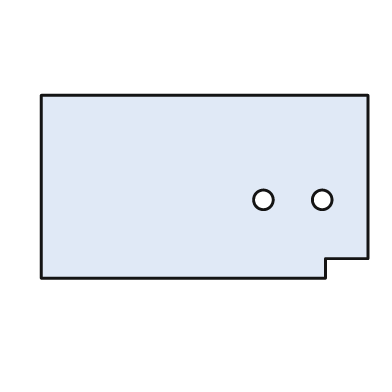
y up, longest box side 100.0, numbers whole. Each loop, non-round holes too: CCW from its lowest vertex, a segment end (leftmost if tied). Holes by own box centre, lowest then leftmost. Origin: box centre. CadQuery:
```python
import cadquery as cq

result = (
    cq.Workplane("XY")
    .moveTo(-50.0, -28.0)
    .lineTo(37.0, -28.0)
    .lineTo(37.0, -22.0)
    .lineTo(50.0, -22.0)
    .lineTo(50.0, 28.0)
    .lineTo(-50.0, 28.0)
    .close()
    .moveTo(18.0, -4.0)
    .circle(3.0)
    .moveTo(36.0, -4.0)
    .circle(3.0)
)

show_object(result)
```